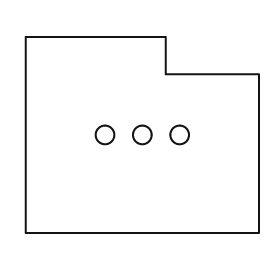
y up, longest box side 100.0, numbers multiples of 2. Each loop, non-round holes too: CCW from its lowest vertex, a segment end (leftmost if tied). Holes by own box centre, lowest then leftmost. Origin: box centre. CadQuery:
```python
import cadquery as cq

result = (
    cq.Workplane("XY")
    .moveTo(-50.0, -42.0)
    .lineTo(50.0, -42.0)
    .lineTo(50.0, 26.0)
    .lineTo(10.0, 26.0)
    .lineTo(10.0, 42.0)
    .lineTo(-50.0, 42.0)
    .close()
    .moveTo(-16.0, 0.0)
    .circle(4.0)
    .moveTo(0.0, 0.0)
    .circle(4.0)
    .moveTo(16.0, 0.0)
    .circle(4.0)
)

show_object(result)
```